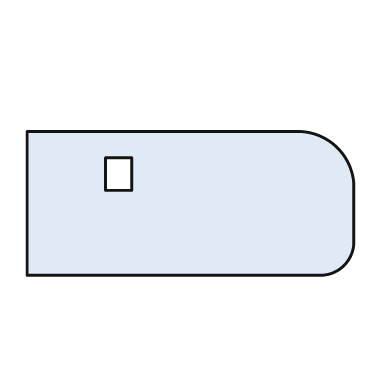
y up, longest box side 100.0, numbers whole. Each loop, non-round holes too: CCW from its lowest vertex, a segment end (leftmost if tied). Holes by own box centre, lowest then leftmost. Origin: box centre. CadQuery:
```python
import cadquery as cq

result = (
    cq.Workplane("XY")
    .moveTo(-50.0, -22.0)
    .lineTo(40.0, -22.0)
    .threePointArc((47.0, -19.0), (50.0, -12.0))
    .lineTo(50.0, 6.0)
    .threePointArc((45.0, 17.0), (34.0, 22.0))
    .lineTo(-50.0, 22.0)
    .close()
    .moveTo(-26.0, 4.0)
    .lineTo(-18.0, 4.0)
    .lineTo(-18.0, 14.0)
    .lineTo(-26.0, 14.0)
    .close()
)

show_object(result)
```